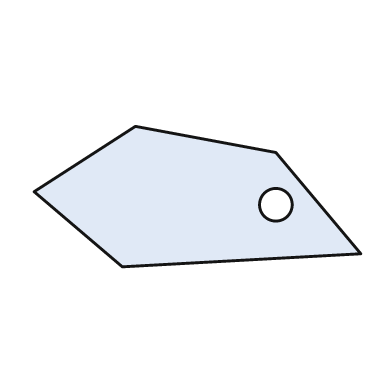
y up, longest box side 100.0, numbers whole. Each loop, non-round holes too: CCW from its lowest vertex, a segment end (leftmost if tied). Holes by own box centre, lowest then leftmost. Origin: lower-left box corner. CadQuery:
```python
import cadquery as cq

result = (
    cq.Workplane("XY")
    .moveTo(27.0, 0.0)
    .lineTo(100.0, 4.0)
    .lineTo(74.0, 35.0)
    .lineTo(31.0, 43.0)
    .lineTo(0.0, 23.0)
    .close()
    .moveTo(74.0, 19.0)
    .circle(5.0)
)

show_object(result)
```